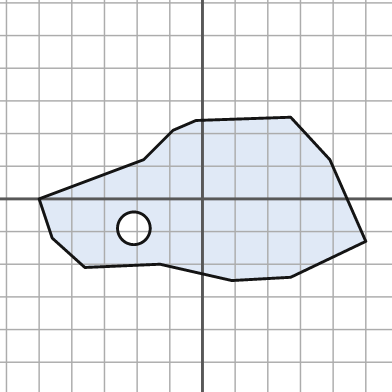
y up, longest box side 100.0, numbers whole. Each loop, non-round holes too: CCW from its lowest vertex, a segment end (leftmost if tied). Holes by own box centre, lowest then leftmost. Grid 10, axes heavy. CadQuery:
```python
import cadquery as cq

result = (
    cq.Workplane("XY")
    .moveTo(9.0, -25.0)
    .lineTo(27.0, -24.0)
    .lineTo(50.0, -13.0)
    .lineTo(39.0, 12.0)
    .lineTo(27.0, 25.0)
    .lineTo(-2.0, 24.0)
    .lineTo(-9.0, 21.0)
    .lineTo(-18.0, 12.0)
    .lineTo(-50.0, 0.0)
    .lineTo(-46.0, -12.0)
    .lineTo(-36.0, -21.0)
    .lineTo(-13.0, -20.0)
    .close()
    .moveTo(-21.0, -9.0)
    .circle(5.0)
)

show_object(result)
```